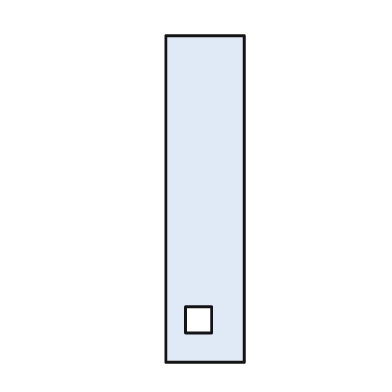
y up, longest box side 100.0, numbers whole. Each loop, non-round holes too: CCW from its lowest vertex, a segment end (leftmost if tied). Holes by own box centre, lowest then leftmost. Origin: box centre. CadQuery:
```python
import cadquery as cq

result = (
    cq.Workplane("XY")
    .moveTo(-12.0, -50.0)
    .lineTo(12.0, -50.0)
    .lineTo(12.0, 50.0)
    .lineTo(-12.0, 50.0)
    .close()
    .moveTo(-6.0, -41.0)
    .lineTo(2.0, -41.0)
    .lineTo(2.0, -33.0)
    .lineTo(-6.0, -33.0)
    .close()
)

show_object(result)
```